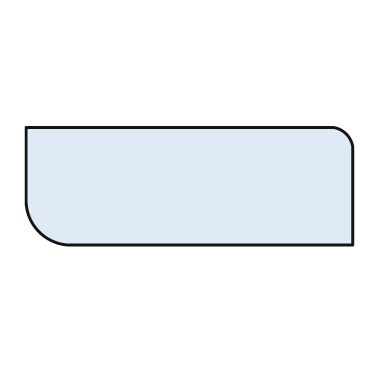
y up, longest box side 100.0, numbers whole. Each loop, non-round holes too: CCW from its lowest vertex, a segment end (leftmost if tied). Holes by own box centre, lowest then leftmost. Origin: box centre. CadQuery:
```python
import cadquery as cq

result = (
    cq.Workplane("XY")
    .moveTo(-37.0, -18.0)
    .lineTo(50.0, -18.0)
    .lineTo(50.0, 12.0)
    .threePointArc((48.0, 16.0), (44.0, 18.0))
    .lineTo(-50.0, 18.0)
    .lineTo(-50.0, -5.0)
    .threePointArc((-46.0, -14.0), (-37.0, -18.0))
    .close()
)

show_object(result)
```